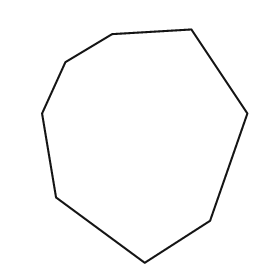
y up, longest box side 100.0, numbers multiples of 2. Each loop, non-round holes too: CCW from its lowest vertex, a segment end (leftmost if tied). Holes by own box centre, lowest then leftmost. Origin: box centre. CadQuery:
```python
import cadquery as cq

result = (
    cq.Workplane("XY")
    .moveTo(0.0, -50.0)
    .lineTo(28.0, -32.0)
    .lineTo(44.0, 14.0)
    .lineTo(20.0, 50.0)
    .lineTo(-14.0, 48.0)
    .lineTo(-34.0, 36.0)
    .lineTo(-44.0, 14.0)
    .lineTo(-38.0, -22.0)
    .close()
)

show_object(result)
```